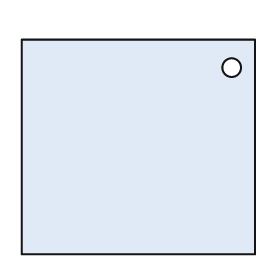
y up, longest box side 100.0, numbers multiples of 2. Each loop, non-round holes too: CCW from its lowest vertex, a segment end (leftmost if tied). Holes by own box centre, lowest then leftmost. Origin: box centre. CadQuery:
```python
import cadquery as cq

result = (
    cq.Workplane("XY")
    .moveTo(-50.0, -46.0)
    .lineTo(50.0, -46.0)
    .lineTo(50.0, 46.0)
    .lineTo(-50.0, 46.0)
    .close()
    .moveTo(40.0, 34.0)
    .circle(4.0)
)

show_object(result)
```